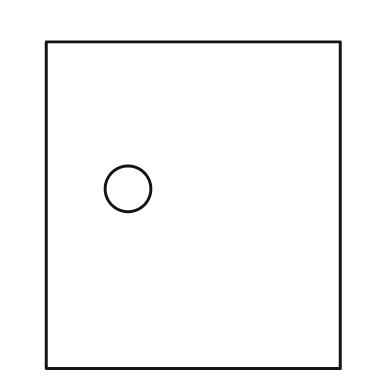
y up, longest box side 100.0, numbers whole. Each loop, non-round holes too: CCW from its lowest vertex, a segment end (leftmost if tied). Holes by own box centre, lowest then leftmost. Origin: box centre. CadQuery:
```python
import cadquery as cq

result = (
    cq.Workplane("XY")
    .moveTo(-45.0, -50.0)
    .lineTo(45.0, -50.0)
    .lineTo(45.0, 50.0)
    .lineTo(-45.0, 50.0)
    .close()
    .moveTo(-20.0, 5.0)
    .circle(7.0)
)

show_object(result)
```